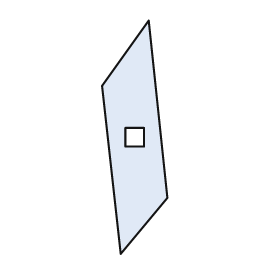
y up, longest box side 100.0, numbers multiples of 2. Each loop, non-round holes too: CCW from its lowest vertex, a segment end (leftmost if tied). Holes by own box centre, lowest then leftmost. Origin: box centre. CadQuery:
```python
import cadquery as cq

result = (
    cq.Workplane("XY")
    .moveTo(-6.0, -50.0)
    .lineTo(14.0, -26.0)
    .lineTo(6.0, 50.0)
    .lineTo(-14.0, 22.0)
    .close()
    .moveTo(-4.0, -4.0)
    .lineTo(4.0, -4.0)
    .lineTo(4.0, 4.0)
    .lineTo(-4.0, 4.0)
    .close()
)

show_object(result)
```